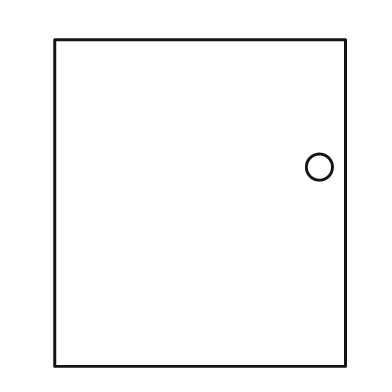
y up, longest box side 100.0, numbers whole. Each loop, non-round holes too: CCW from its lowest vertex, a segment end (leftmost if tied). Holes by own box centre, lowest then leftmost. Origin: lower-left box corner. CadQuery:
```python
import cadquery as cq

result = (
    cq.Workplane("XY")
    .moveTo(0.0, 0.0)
    .lineTo(89.0, 0.0)
    .lineTo(89.0, 100.0)
    .lineTo(0.0, 100.0)
    .close()
    .moveTo(81.0, 61.0)
    .circle(4.0)
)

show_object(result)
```